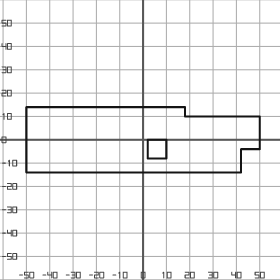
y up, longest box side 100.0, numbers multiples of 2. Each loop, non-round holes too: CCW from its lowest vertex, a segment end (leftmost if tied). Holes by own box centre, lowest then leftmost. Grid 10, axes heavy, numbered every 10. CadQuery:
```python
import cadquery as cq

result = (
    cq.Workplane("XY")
    .moveTo(-50.0, -14.0)
    .lineTo(42.0, -14.0)
    .lineTo(42.0, -4.0)
    .lineTo(50.0, -4.0)
    .lineTo(50.0, 10.0)
    .lineTo(18.0, 10.0)
    .lineTo(18.0, 14.0)
    .lineTo(-50.0, 14.0)
    .close()
    .moveTo(2.0, -8.0)
    .lineTo(10.0, -8.0)
    .lineTo(10.0, 0.0)
    .lineTo(2.0, 0.0)
    .close()
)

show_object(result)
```